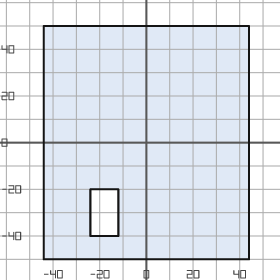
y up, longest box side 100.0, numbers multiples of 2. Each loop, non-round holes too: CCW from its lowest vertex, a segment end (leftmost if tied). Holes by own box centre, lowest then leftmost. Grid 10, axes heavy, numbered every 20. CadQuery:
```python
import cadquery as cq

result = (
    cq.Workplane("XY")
    .moveTo(-44.0, -50.0)
    .lineTo(44.0, -50.0)
    .lineTo(44.0, 50.0)
    .lineTo(-44.0, 50.0)
    .close()
    .moveTo(-24.0, -40.0)
    .lineTo(-12.0, -40.0)
    .lineTo(-12.0, -20.0)
    .lineTo(-24.0, -20.0)
    .close()
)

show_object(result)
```